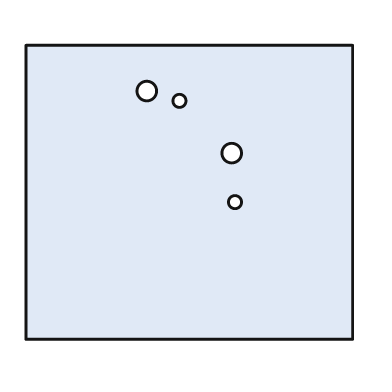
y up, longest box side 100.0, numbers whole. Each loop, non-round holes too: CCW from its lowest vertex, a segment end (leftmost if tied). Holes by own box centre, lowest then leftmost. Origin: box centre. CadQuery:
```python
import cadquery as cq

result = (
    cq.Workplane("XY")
    .moveTo(-50.0, -45.0)
    .lineTo(50.0, -45.0)
    .lineTo(50.0, 45.0)
    .lineTo(-50.0, 45.0)
    .close()
    .moveTo(14.0, -3.0)
    .circle(2.0)
    .moveTo(13.0, 12.0)
    .circle(3.0)
    .moveTo(-3.0, 28.0)
    .circle(2.0)
    .moveTo(-13.0, 31.0)
    .circle(3.0)
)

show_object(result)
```